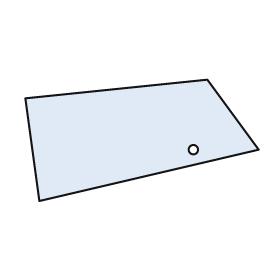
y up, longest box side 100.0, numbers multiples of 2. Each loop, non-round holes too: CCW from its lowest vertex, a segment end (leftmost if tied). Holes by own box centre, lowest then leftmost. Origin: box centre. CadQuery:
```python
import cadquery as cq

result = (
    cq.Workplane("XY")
    .moveTo(-44.0, -26.0)
    .lineTo(50.0, -4.0)
    .lineTo(28.0, 26.0)
    .lineTo(-50.0, 18.0)
    .close()
    .moveTo(22.0, -4.0)
    .circle(2.0)
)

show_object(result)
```